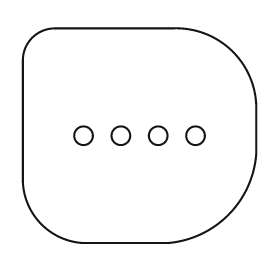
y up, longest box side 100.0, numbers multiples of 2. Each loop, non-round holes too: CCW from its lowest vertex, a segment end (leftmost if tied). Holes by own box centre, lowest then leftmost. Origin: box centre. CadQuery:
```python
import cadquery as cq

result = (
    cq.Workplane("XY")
    .moveTo(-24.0, -46.0)
    .lineTo(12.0, -46.0)
    .threePointArc((38.0, -34.0), (50.0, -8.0))
    .lineTo(50.0, 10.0)
    .threePointArc((40.0, 36.0), (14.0, 46.0))
    .lineTo(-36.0, 46.0)
    .threePointArc((-46.0, 42.0), (-50.0, 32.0))
    .lineTo(-50.0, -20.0)
    .threePointArc((-42.0, -38.0), (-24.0, -46.0))
    .close()
    .moveTo(-24.0, 0.0)
    .circle(4.0)
    .moveTo(-8.0, 0.0)
    .circle(4.0)
    .moveTo(8.0, 0.0)
    .circle(4.0)
    .moveTo(24.0, 0.0)
    .circle(4.0)
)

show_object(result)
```